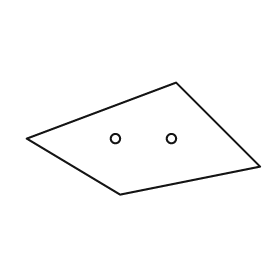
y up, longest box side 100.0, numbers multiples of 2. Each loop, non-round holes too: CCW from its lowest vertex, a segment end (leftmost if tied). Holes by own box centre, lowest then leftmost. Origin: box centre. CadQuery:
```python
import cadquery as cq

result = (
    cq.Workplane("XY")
    .moveTo(-10.0, -24.0)
    .lineTo(50.0, -12.0)
    .lineTo(14.0, 24.0)
    .lineTo(-50.0, 0.0)
    .close()
    .moveTo(-12.0, 0.0)
    .circle(2.0)
    .moveTo(12.0, 0.0)
    .circle(2.0)
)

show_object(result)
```